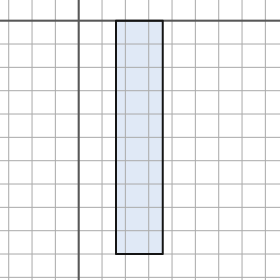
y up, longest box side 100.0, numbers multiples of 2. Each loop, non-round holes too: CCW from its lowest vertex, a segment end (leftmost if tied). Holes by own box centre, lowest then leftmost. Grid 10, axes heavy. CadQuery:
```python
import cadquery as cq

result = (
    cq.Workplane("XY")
    .moveTo(16.0, -100.0)
    .lineTo(36.0, -100.0)
    .lineTo(36.0, 0.0)
    .lineTo(16.0, 0.0)
    .close()
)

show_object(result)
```